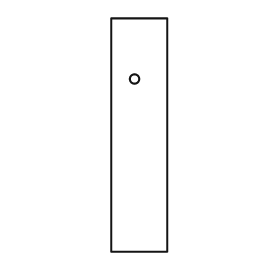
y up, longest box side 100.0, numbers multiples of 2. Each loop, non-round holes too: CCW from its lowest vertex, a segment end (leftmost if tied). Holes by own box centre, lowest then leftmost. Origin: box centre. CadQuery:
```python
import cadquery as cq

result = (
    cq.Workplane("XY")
    .moveTo(-12.0, -50.0)
    .lineTo(12.0, -50.0)
    .lineTo(12.0, 50.0)
    .lineTo(-12.0, 50.0)
    .close()
    .moveTo(-2.0, 24.0)
    .circle(2.0)
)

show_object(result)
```